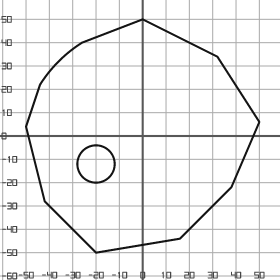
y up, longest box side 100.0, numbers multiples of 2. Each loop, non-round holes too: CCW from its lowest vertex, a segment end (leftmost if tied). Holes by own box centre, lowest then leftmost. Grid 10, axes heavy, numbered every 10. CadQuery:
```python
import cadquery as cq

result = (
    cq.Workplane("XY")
    .moveTo(-20.0, -50.0)
    .lineTo(16.0, -44.0)
    .lineTo(38.0, -22.0)
    .lineTo(50.0, 6.0)
    .lineTo(32.0, 34.0)
    .lineTo(0.0, 50.0)
    .lineTo(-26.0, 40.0)
    .threePointArc((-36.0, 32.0), (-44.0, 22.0))
    .lineTo(-50.0, 4.0)
    .lineTo(-42.0, -28.0)
    .close()
    .moveTo(-20.0, -12.0)
    .circle(8.0)
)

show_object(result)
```